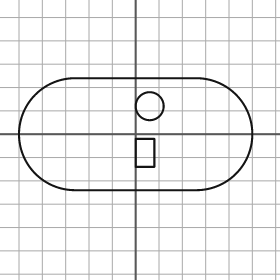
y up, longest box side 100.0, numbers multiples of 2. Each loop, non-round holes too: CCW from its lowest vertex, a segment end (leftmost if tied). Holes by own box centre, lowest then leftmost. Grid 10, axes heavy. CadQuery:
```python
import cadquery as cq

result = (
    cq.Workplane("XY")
    .moveTo(-26.0, -24.0)
    .lineTo(26.0, -24.0)
    .threePointArc((50.0, 0.0), (26.0, 24.0))
    .lineTo(-26.0, 24.0)
    .threePointArc((-50.0, 0.0), (-26.0, -24.0))
    .close()
    .moveTo(0.0, -14.0)
    .lineTo(8.0, -14.0)
    .lineTo(8.0, -2.0)
    .lineTo(0.0, -2.0)
    .close()
    .moveTo(6.0, 12.0)
    .circle(6.0)
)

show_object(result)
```